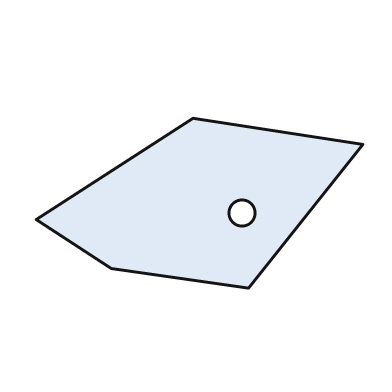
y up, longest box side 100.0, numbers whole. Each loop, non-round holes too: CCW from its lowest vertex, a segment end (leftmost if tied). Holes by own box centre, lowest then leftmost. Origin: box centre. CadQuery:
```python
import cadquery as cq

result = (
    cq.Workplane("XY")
    .moveTo(15.0, -26.0)
    .lineTo(50.0, 18.0)
    .lineTo(-2.0, 26.0)
    .lineTo(-50.0, -5.0)
    .lineTo(-27.0, -20.0)
    .close()
    .moveTo(13.0, -3.0)
    .circle(4.0)
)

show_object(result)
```